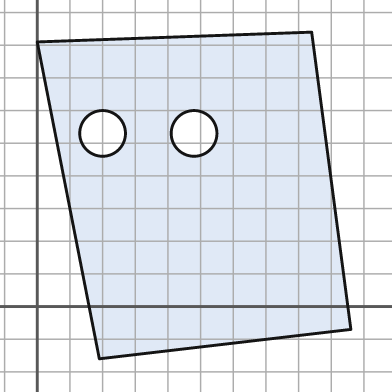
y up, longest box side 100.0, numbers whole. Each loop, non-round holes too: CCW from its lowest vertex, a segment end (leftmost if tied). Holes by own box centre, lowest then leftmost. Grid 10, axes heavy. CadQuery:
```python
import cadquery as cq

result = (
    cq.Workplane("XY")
    .moveTo(19.0, -16.0)
    .lineTo(96.0, -7.0)
    .lineTo(84.0, 84.0)
    .lineTo(0.0, 81.0)
    .close()
    .moveTo(20.0, 53.0)
    .circle(7.0)
    .moveTo(48.0, 53.0)
    .circle(7.0)
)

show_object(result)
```